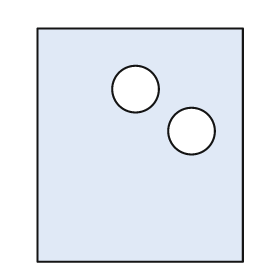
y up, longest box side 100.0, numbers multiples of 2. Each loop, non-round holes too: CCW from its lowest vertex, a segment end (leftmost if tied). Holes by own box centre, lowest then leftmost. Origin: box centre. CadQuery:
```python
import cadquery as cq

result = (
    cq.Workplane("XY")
    .moveTo(-44.0, -50.0)
    .lineTo(44.0, -50.0)
    .lineTo(44.0, 50.0)
    .lineTo(-44.0, 50.0)
    .close()
    .moveTo(22.0, 6.0)
    .circle(10.0)
    .moveTo(-2.0, 24.0)
    .circle(10.0)
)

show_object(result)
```